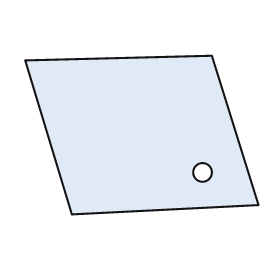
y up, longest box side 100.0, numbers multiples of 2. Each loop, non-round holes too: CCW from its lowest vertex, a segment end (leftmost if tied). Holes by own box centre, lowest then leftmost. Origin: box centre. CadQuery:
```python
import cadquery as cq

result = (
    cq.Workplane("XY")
    .moveTo(-30.0, -34.0)
    .lineTo(50.0, -30.0)
    .lineTo(30.0, 34.0)
    .lineTo(-50.0, 32.0)
    .close()
    .moveTo(26.0, -16.0)
    .circle(4.0)
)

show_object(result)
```